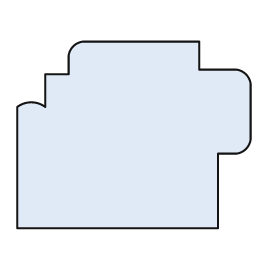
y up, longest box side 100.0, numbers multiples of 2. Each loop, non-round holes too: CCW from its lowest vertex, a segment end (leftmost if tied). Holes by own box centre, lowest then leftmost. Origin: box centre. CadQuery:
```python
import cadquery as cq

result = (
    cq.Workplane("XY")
    .moveTo(-50.0, -40.0)
    .lineTo(36.0, -40.0)
    .lineTo(36.0, -8.0)
    .lineTo(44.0, -8.0)
    .threePointArc((48.0, -6.0), (50.0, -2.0))
    .lineTo(50.0, 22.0)
    .threePointArc((48.0, 26.0), (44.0, 28.0))
    .lineTo(28.0, 28.0)
    .lineTo(28.0, 40.0)
    .lineTo(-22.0, 40.0)
    .threePointArc((-26.0, 38.0), (-28.0, 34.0))
    .lineTo(-28.0, 26.0)
    .lineTo(-38.0, 26.0)
    .lineTo(-38.0, 12.0)
    .threePointArc((-44.0, 14.0), (-50.0, 12.0))
    .close()
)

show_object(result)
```